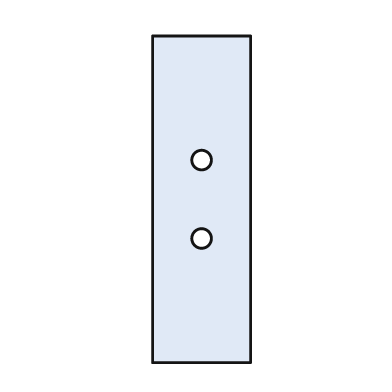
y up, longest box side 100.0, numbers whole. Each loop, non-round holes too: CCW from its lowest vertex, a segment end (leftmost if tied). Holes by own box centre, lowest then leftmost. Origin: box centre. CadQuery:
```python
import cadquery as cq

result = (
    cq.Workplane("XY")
    .moveTo(-15.0, -50.0)
    .lineTo(15.0, -50.0)
    .lineTo(15.0, 50.0)
    .lineTo(-15.0, 50.0)
    .close()
    .moveTo(0.0, -12.0)
    .circle(3.0)
    .moveTo(0.0, 12.0)
    .circle(3.0)
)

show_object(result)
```